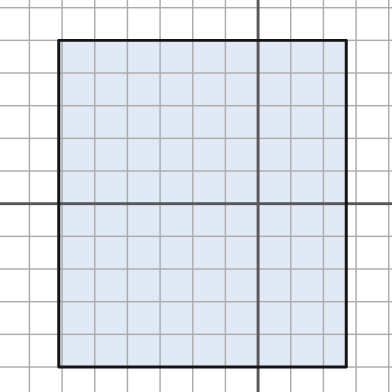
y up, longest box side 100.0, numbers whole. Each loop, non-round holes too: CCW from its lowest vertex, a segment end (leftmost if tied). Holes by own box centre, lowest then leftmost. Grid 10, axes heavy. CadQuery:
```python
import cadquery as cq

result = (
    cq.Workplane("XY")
    .moveTo(-61.0, -50.0)
    .lineTo(27.0, -50.0)
    .lineTo(27.0, 50.0)
    .lineTo(-61.0, 50.0)
    .close()
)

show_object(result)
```